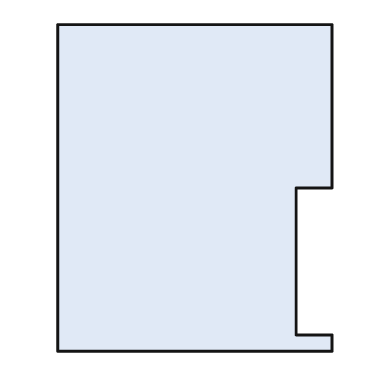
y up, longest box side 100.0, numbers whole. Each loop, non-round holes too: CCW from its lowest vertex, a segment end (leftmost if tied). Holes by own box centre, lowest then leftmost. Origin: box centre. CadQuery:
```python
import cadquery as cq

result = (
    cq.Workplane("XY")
    .moveTo(-42.0, -50.0)
    .lineTo(42.0, -50.0)
    .lineTo(42.0, -45.0)
    .lineTo(31.0, -45.0)
    .lineTo(31.0, 0.0)
    .lineTo(42.0, 0.0)
    .lineTo(42.0, 50.0)
    .lineTo(-42.0, 50.0)
    .close()
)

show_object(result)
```